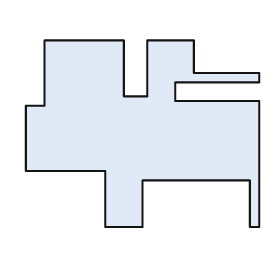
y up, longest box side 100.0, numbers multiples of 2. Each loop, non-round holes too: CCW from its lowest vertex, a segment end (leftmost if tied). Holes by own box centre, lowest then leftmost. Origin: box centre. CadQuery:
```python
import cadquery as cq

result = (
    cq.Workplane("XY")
    .moveTo(-16.0, -40.0)
    .lineTo(0.0, -40.0)
    .lineTo(0.0, -20.0)
    .lineTo(46.0, -20.0)
    .lineTo(46.0, -40.0)
    .lineTo(50.0, -40.0)
    .lineTo(50.0, 14.0)
    .lineTo(14.0, 14.0)
    .lineTo(14.0, 22.0)
    .lineTo(50.0, 22.0)
    .lineTo(50.0, 26.0)
    .lineTo(22.0, 26.0)
    .lineTo(22.0, 40.0)
    .lineTo(2.0, 40.0)
    .lineTo(2.0, 16.0)
    .lineTo(-8.0, 16.0)
    .lineTo(-8.0, 40.0)
    .lineTo(-42.0, 40.0)
    .lineTo(-42.0, 12.0)
    .lineTo(-50.0, 12.0)
    .lineTo(-50.0, -16.0)
    .lineTo(-16.0, -16.0)
    .close()
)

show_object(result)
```